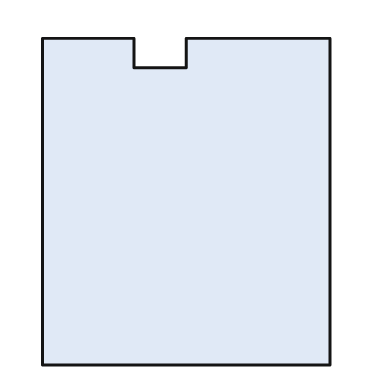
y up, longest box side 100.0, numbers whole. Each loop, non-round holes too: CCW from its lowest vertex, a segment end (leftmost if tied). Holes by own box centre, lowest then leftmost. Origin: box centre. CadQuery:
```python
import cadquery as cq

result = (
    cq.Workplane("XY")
    .moveTo(-44.0, -50.0)
    .lineTo(44.0, -50.0)
    .lineTo(44.0, 50.0)
    .lineTo(0.0, 50.0)
    .lineTo(0.0, 41.0)
    .lineTo(-16.0, 41.0)
    .lineTo(-16.0, 50.0)
    .lineTo(-44.0, 50.0)
    .close()
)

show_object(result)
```